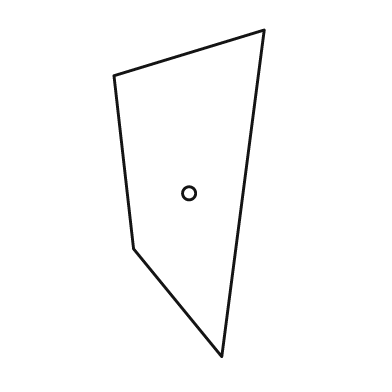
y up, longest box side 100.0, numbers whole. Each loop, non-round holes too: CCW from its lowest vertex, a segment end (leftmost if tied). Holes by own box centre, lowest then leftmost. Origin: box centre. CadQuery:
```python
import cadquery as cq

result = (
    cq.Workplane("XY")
    .moveTo(10.0, -50.0)
    .lineTo(23.0, 50.0)
    .lineTo(-23.0, 36.0)
    .lineTo(-17.0, -17.0)
    .close()
    .moveTo(0.0, 0.0)
    .circle(2.0)
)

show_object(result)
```